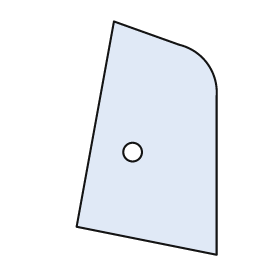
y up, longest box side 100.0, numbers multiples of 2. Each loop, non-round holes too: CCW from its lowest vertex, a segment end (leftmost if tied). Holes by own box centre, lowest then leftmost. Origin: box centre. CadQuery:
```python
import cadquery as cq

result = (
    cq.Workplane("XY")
    .moveTo(30.0, -50.0)
    .lineTo(30.0, 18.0)
    .threePointArc((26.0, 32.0), (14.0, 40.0))
    .lineTo(-14.0, 50.0)
    .lineTo(-30.0, -38.0)
    .close()
    .moveTo(-6.0, -6.0)
    .circle(4.0)
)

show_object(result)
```